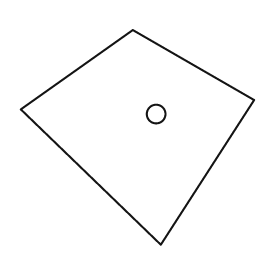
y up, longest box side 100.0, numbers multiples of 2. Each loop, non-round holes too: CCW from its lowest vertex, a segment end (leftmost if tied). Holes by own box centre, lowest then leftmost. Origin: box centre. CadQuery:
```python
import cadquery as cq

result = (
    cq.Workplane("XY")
    .moveTo(10.0, -46.0)
    .lineTo(50.0, 16.0)
    .lineTo(-2.0, 46.0)
    .lineTo(-50.0, 12.0)
    .close()
    .moveTo(8.0, 10.0)
    .circle(4.0)
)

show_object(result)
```